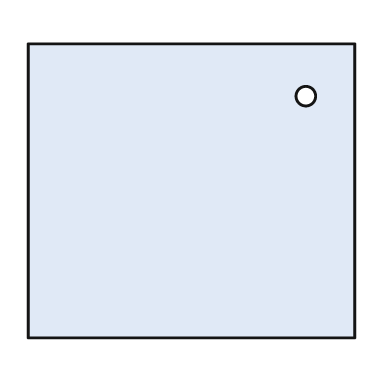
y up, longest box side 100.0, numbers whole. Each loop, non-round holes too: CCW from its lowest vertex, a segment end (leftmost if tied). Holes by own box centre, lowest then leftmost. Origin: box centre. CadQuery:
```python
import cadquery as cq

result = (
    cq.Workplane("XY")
    .moveTo(-50.0, -45.0)
    .lineTo(50.0, -45.0)
    .lineTo(50.0, 45.0)
    .lineTo(-50.0, 45.0)
    .close()
    .moveTo(35.0, 29.0)
    .circle(3.0)
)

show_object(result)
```